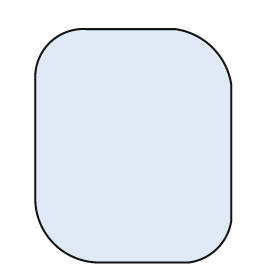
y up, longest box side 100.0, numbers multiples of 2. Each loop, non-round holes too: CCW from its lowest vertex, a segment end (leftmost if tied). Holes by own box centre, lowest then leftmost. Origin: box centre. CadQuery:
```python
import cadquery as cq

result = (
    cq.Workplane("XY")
    .moveTo(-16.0, -50.0)
    .lineTo(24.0, -50.0)
    .threePointArc((36.0, -44.0), (42.0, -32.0))
    .lineTo(42.0, 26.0)
    .threePointArc((34.0, 42.0), (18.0, 50.0))
    .lineTo(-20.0, 50.0)
    .threePointArc((-36.0, 44.0), (-42.0, 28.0))
    .lineTo(-42.0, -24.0)
    .threePointArc((-34.0, -42.0), (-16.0, -50.0))
    .close()
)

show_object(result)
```